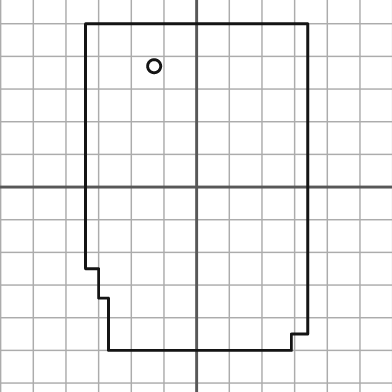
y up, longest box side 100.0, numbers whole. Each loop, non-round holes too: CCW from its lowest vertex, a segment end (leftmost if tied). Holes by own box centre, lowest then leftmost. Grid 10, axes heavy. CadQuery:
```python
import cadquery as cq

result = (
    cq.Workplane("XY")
    .moveTo(-27.0, -50.0)
    .lineTo(29.0, -50.0)
    .lineTo(29.0, -45.0)
    .lineTo(34.0, -45.0)
    .lineTo(34.0, 50.0)
    .lineTo(-34.0, 50.0)
    .lineTo(-34.0, -25.0)
    .lineTo(-30.0, -25.0)
    .lineTo(-30.0, -34.0)
    .lineTo(-27.0, -34.0)
    .close()
    .moveTo(-13.0, 37.0)
    .circle(2.0)
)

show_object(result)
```